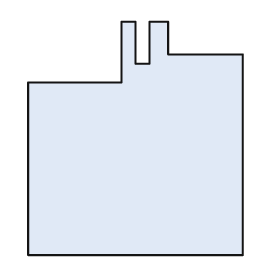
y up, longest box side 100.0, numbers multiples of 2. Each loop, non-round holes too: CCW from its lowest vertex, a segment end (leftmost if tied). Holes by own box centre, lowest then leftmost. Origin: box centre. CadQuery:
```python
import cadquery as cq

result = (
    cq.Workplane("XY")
    .moveTo(-46.0, -50.0)
    .lineTo(46.0, -50.0)
    .lineTo(46.0, 36.0)
    .lineTo(14.0, 36.0)
    .lineTo(14.0, 50.0)
    .lineTo(6.0, 50.0)
    .lineTo(6.0, 32.0)
    .lineTo(0.0, 32.0)
    .lineTo(0.0, 50.0)
    .lineTo(-6.0, 50.0)
    .lineTo(-6.0, 24.0)
    .lineTo(-46.0, 24.0)
    .close()
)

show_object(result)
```